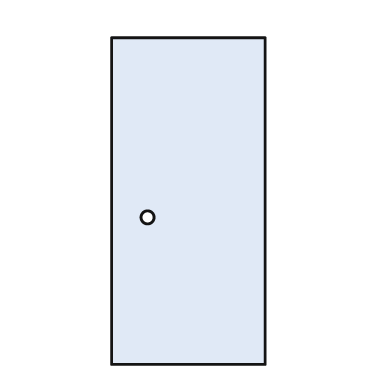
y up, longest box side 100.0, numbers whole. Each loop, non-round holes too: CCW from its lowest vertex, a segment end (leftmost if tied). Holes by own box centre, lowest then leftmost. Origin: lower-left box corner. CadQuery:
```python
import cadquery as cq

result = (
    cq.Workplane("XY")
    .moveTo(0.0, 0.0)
    .lineTo(47.0, 0.0)
    .lineTo(47.0, 100.0)
    .lineTo(0.0, 100.0)
    .close()
    .moveTo(11.0, 45.0)
    .circle(2.0)
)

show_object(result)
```